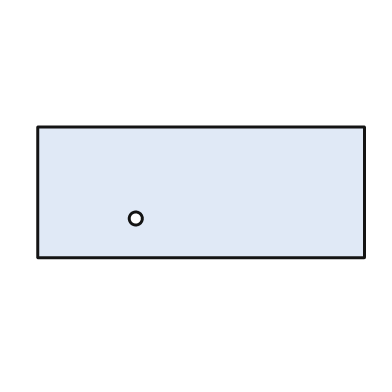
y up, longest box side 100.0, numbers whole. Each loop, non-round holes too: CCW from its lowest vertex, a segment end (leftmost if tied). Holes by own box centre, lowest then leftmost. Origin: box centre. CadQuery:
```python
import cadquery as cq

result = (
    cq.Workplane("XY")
    .moveTo(-50.0, -20.0)
    .lineTo(50.0, -20.0)
    .lineTo(50.0, 20.0)
    .lineTo(-50.0, 20.0)
    .close()
    .moveTo(-20.0, -8.0)
    .circle(2.0)
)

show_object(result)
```